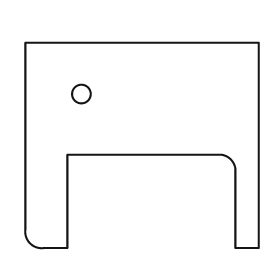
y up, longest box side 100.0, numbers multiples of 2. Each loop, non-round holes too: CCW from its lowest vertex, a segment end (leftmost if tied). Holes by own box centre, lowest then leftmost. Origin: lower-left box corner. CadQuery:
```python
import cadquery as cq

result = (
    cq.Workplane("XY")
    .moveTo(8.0, 0.0)
    .lineTo(18.0, 0.0)
    .lineTo(18.0, 40.0)
    .lineTo(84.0, 40.0)
    .threePointArc((88.0, 38.0), (90.0, 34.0))
    .lineTo(90.0, 0.0)
    .lineTo(100.0, 0.0)
    .lineTo(100.0, 88.0)
    .lineTo(0.0, 88.0)
    .lineTo(0.0, 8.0)
    .threePointArc((2.0, 2.0), (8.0, 0.0))
    .close()
    .moveTo(24.0, 66.0)
    .circle(4.0)
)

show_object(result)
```